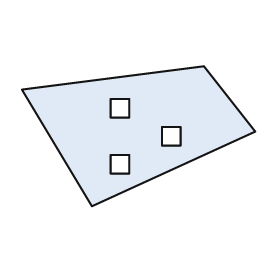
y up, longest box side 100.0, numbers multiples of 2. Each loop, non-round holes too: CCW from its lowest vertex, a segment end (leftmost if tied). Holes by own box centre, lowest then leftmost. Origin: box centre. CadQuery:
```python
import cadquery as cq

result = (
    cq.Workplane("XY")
    .moveTo(-20.0, -30.0)
    .lineTo(50.0, 2.0)
    .lineTo(28.0, 30.0)
    .lineTo(-50.0, 20.0)
    .close()
    .moveTo(-12.0, -16.0)
    .lineTo(-4.0, -16.0)
    .lineTo(-4.0, -8.0)
    .lineTo(-12.0, -8.0)
    .close()
    .moveTo(10.0, -4.0)
    .lineTo(18.0, -4.0)
    .lineTo(18.0, 4.0)
    .lineTo(10.0, 4.0)
    .close()
    .moveTo(-12.0, 8.0)
    .lineTo(-4.0, 8.0)
    .lineTo(-4.0, 16.0)
    .lineTo(-12.0, 16.0)
    .close()
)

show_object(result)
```